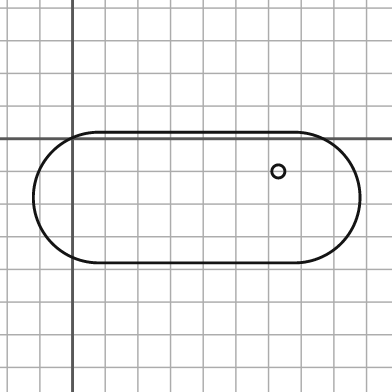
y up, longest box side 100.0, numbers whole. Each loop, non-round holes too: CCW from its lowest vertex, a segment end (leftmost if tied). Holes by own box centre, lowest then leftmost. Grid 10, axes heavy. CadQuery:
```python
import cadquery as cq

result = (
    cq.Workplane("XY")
    .moveTo(8.0, -38.0)
    .lineTo(68.0, -38.0)
    .threePointArc((88.0, -18.0), (68.0, 2.0))
    .lineTo(8.0, 2.0)
    .threePointArc((-12.0, -18.0), (8.0, -38.0))
    .close()
    .moveTo(63.0, -10.0)
    .circle(2.0)
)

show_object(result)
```